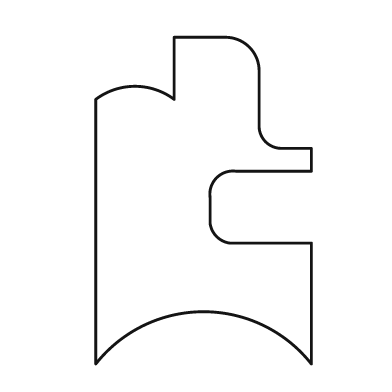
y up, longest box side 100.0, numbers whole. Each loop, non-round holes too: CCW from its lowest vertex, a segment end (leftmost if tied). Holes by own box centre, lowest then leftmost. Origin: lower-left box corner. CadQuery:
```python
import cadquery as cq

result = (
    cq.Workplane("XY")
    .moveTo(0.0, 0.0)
    .threePointArc((33.0, 16.0), (66.0, 0.0))
    .lineTo(66.0, 37.0)
    .lineTo(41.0, 37.0)
    .threePointArc((37.0, 39.0), (35.0, 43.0))
    .lineTo(35.0, 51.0)
    .threePointArc((37.0, 57.0), (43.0, 59.0))
    .lineTo(66.0, 59.0)
    .lineTo(66.0, 66.0)
    .lineTo(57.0, 66.0)
    .threePointArc((52.0, 68.0), (50.0, 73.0))
    .lineTo(50.0, 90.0)
    .threePointArc((47.0, 97.0), (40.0, 100.0))
    .lineTo(24.0, 100.0)
    .lineTo(24.0, 81.0)
    .threePointArc((12.0, 85.0), (0.0, 81.0))
    .close()
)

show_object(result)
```